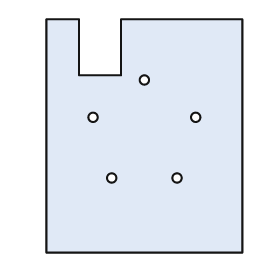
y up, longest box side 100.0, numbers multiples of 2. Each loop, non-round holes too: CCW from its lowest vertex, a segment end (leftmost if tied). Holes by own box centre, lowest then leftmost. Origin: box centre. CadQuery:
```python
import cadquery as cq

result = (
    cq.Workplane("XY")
    .moveTo(-42.0, -50.0)
    .lineTo(42.0, -50.0)
    .lineTo(42.0, 50.0)
    .lineTo(-10.0, 50.0)
    .lineTo(-10.0, 26.0)
    .lineTo(-28.0, 26.0)
    .lineTo(-28.0, 50.0)
    .lineTo(-42.0, 50.0)
    .close()
    .moveTo(-14.0, -18.0)
    .circle(2.0)
    .moveTo(14.0, -18.0)
    .circle(2.0)
    .moveTo(-22.0, 8.0)
    .circle(2.0)
    .moveTo(22.0, 8.0)
    .circle(2.0)
    .moveTo(0.0, 24.0)
    .circle(2.0)
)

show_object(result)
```